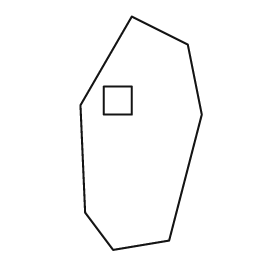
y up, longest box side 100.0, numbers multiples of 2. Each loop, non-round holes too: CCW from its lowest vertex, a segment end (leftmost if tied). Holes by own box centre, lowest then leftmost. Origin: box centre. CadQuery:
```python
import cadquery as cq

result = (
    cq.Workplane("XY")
    .moveTo(-12.0, -50.0)
    .lineTo(12.0, -46.0)
    .lineTo(26.0, 8.0)
    .lineTo(20.0, 38.0)
    .lineTo(-4.0, 50.0)
    .lineTo(-26.0, 12.0)
    .lineTo(-24.0, -34.0)
    .close()
    .moveTo(-16.0, 8.0)
    .lineTo(-4.0, 8.0)
    .lineTo(-4.0, 20.0)
    .lineTo(-16.0, 20.0)
    .close()
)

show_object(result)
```